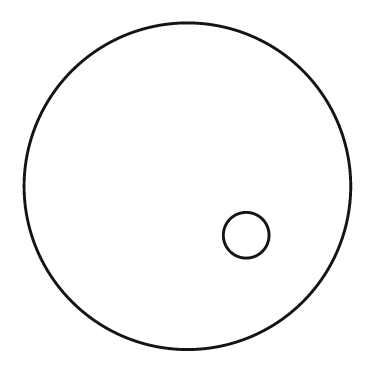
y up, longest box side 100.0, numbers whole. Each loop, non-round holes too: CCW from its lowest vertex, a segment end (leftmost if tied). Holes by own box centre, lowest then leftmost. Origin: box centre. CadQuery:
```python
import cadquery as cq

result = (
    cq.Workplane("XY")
    .moveTo(0.0, 0.0)
    .circle(50.0)
    .moveTo(18.0, -15.0)
    .circle(7.0)
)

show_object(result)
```